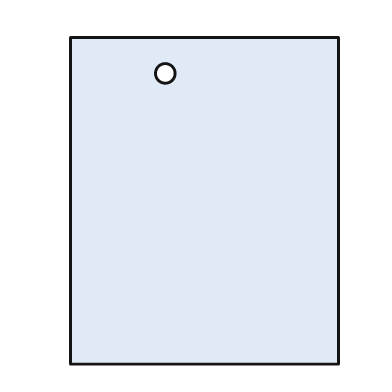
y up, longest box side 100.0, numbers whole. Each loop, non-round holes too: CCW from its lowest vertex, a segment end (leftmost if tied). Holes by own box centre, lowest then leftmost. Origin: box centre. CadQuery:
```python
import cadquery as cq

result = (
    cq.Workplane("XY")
    .moveTo(-41.0, -50.0)
    .lineTo(41.0, -50.0)
    .lineTo(41.0, 50.0)
    .lineTo(-41.0, 50.0)
    .close()
    .moveTo(-12.0, 39.0)
    .circle(3.0)
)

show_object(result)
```